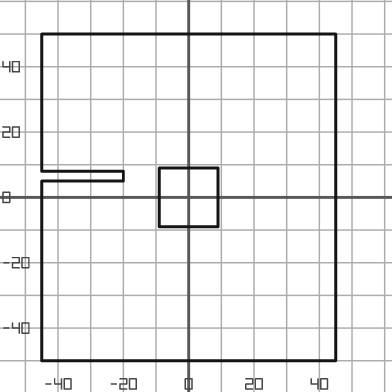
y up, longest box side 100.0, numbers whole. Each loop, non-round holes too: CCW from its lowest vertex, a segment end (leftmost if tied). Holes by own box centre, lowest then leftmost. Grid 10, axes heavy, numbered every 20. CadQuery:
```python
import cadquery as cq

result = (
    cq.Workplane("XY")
    .moveTo(-45.0, -50.0)
    .lineTo(45.0, -50.0)
    .lineTo(45.0, 50.0)
    .lineTo(-45.0, 50.0)
    .lineTo(-45.0, 8.0)
    .lineTo(-20.0, 8.0)
    .lineTo(-20.0, 5.0)
    .lineTo(-45.0, 5.0)
    .close()
    .moveTo(-9.0, -9.0)
    .lineTo(9.0, -9.0)
    .lineTo(9.0, 9.0)
    .lineTo(-9.0, 9.0)
    .close()
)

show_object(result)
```